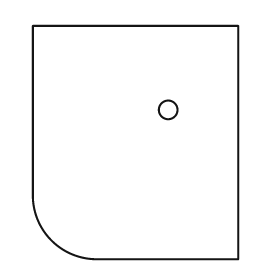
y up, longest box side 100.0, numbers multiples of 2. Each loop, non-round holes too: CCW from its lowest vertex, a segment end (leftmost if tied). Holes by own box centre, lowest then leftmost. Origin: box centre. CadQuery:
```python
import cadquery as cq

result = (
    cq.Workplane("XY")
    .moveTo(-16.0, -50.0)
    .lineTo(44.0, -50.0)
    .lineTo(44.0, 50.0)
    .lineTo(-44.0, 50.0)
    .lineTo(-44.0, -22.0)
    .threePointArc((-36.0, -42.0), (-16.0, -50.0))
    .close()
    .moveTo(14.0, 14.0)
    .circle(4.0)
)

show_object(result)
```